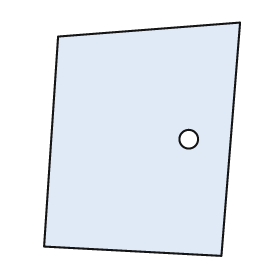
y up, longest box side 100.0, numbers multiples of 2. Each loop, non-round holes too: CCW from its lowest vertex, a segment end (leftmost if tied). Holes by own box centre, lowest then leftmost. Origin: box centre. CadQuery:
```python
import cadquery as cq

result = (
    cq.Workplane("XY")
    .moveTo(34.0, -50.0)
    .lineTo(42.0, 50.0)
    .lineTo(-36.0, 44.0)
    .lineTo(-42.0, -46.0)
    .close()
    .moveTo(20.0, 0.0)
    .circle(4.0)
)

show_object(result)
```